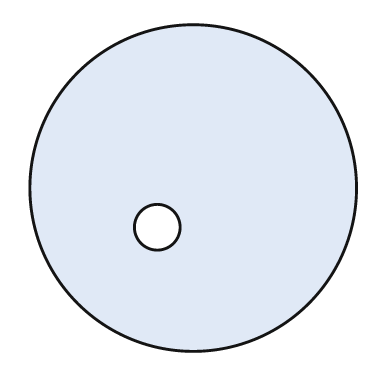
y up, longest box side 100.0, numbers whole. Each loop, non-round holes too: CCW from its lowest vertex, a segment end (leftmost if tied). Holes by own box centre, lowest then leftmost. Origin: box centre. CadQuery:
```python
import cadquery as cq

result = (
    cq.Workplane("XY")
    .moveTo(0.0, 0.0)
    .circle(50.0)
    .moveTo(-11.0, -12.0)
    .circle(7.0)
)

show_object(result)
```